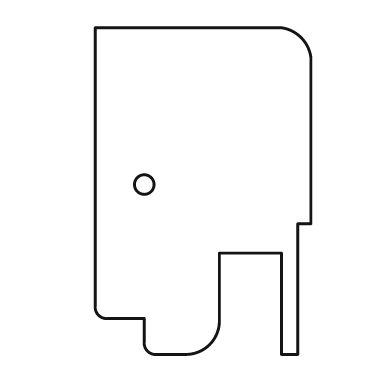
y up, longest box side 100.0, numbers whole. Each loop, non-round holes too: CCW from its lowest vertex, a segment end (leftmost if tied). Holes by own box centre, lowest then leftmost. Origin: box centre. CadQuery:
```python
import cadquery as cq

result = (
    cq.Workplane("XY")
    .moveTo(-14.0, -50.0)
    .lineTo(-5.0, -50.0)
    .threePointArc((2.0, -47.0), (5.0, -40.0))
    .lineTo(5.0, -19.0)
    .lineTo(24.0, -19.0)
    .lineTo(24.0, -50.0)
    .lineTo(29.0, -50.0)
    .lineTo(29.0, -10.0)
    .lineTo(33.0, -10.0)
    .lineTo(33.0, 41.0)
    .threePointArc((30.0, 47.0), (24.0, 50.0))
    .lineTo(-33.0, 50.0)
    .lineTo(-33.0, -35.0)
    .threePointArc((-32.0, -38.0), (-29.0, -39.0))
    .lineTo(-18.0, -39.0)
    .lineTo(-18.0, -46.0)
    .threePointArc((-17.0, -49.0), (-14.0, -50.0))
    .close()
    .moveTo(-18.0, 2.0)
    .circle(3.0)
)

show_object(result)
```